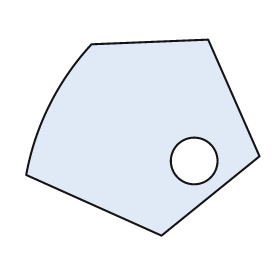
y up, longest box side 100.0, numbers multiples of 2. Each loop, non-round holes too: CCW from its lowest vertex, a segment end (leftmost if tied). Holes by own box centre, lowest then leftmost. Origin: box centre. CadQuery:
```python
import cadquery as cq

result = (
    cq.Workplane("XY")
    .moveTo(8.0, -42.0)
    .lineTo(50.0, -8.0)
    .lineTo(28.0, 42.0)
    .lineTo(-22.0, 40.0)
    .threePointArc((-40.0, 14.0), (-50.0, -16.0))
    .close()
    .moveTo(22.0, -10.0)
    .circle(10.0)
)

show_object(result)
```